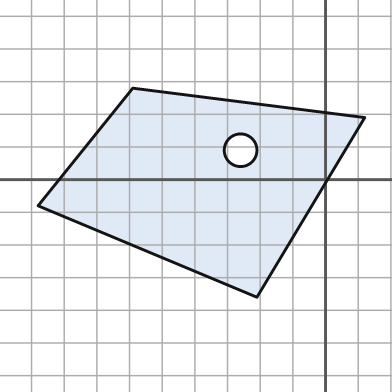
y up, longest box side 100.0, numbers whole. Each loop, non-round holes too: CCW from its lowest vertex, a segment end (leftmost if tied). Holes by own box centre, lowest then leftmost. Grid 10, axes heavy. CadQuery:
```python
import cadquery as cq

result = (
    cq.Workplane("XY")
    .moveTo(-21.0, -36.0)
    .lineTo(12.0, 19.0)
    .lineTo(-59.0, 28.0)
    .lineTo(-88.0, -8.0)
    .close()
    .moveTo(-26.0, 9.0)
    .circle(5.0)
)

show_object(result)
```